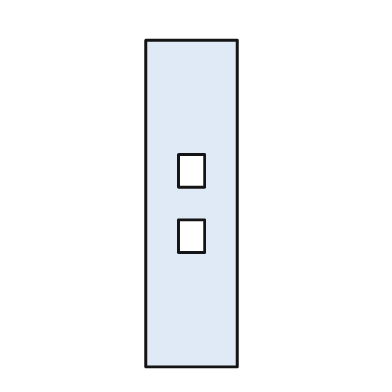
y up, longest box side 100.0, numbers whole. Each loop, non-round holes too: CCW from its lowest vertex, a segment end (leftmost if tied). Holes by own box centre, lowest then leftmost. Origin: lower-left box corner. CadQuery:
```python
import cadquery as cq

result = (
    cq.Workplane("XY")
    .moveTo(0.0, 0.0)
    .lineTo(28.0, 0.0)
    .lineTo(28.0, 100.0)
    .lineTo(0.0, 100.0)
    .close()
    .moveTo(10.0, 35.0)
    .lineTo(18.0, 35.0)
    .lineTo(18.0, 45.0)
    .lineTo(10.0, 45.0)
    .close()
    .moveTo(10.0, 55.0)
    .lineTo(18.0, 55.0)
    .lineTo(18.0, 65.0)
    .lineTo(10.0, 65.0)
    .close()
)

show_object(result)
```